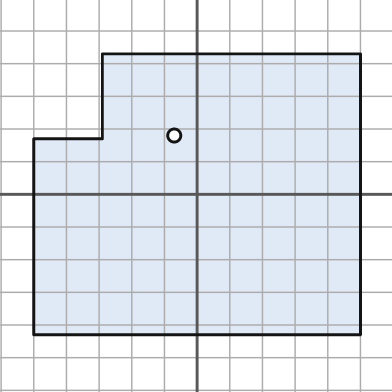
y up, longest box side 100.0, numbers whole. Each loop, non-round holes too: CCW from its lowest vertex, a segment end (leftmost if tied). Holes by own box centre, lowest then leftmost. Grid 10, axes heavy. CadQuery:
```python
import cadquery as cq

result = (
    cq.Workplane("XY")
    .moveTo(-50.0, -43.0)
    .lineTo(50.0, -43.0)
    .lineTo(50.0, 43.0)
    .lineTo(-29.0, 43.0)
    .lineTo(-29.0, 17.0)
    .lineTo(-50.0, 17.0)
    .close()
    .moveTo(-7.0, 18.0)
    .circle(2.0)
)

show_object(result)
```